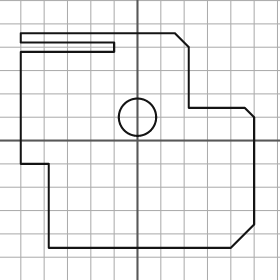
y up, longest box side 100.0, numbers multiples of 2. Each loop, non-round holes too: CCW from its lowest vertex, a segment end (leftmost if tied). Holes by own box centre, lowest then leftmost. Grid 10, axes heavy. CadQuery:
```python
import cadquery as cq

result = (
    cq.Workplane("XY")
    .moveTo(-38.0, -46.0)
    .lineTo(40.0, -46.0)
    .lineTo(50.0, -36.0)
    .lineTo(50.0, 10.0)
    .lineTo(46.0, 14.0)
    .lineTo(22.0, 14.0)
    .lineTo(22.0, 40.0)
    .lineTo(16.0, 46.0)
    .lineTo(-50.0, 46.0)
    .lineTo(-50.0, 42.0)
    .lineTo(-10.0, 42.0)
    .lineTo(-10.0, 38.0)
    .lineTo(-50.0, 38.0)
    .lineTo(-50.0, -10.0)
    .lineTo(-38.0, -10.0)
    .close()
    .moveTo(0.0, 10.0)
    .circle(8.0)
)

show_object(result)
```